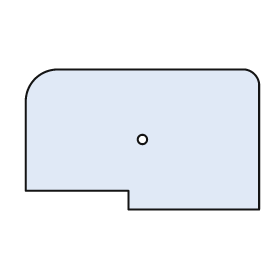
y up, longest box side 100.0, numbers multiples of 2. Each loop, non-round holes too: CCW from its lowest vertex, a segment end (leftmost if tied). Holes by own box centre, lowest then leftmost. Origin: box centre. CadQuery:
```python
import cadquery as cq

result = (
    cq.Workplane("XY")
    .moveTo(-6.0, -30.0)
    .lineTo(50.0, -30.0)
    .lineTo(50.0, 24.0)
    .threePointArc((48.0, 28.0), (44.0, 30.0))
    .lineTo(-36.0, 30.0)
    .threePointArc((-46.0, 26.0), (-50.0, 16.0))
    .lineTo(-50.0, -22.0)
    .lineTo(-6.0, -22.0)
    .close()
    .moveTo(0.0, 0.0)
    .circle(2.0)
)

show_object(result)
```